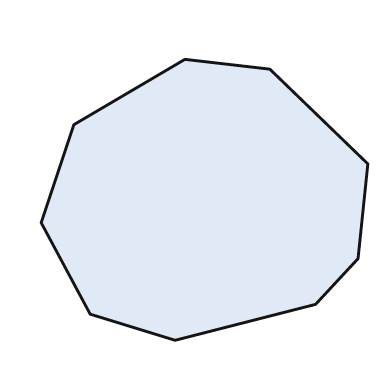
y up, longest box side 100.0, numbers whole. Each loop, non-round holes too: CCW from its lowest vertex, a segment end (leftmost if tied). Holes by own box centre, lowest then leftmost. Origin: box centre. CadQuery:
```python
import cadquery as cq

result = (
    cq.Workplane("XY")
    .moveTo(-9.0, -43.0)
    .lineTo(34.0, -32.0)
    .lineTo(47.0, -18.0)
    .lineTo(50.0, 11.0)
    .lineTo(20.0, 40.0)
    .lineTo(-6.0, 43.0)
    .lineTo(-40.0, 23.0)
    .lineTo(-50.0, -7.0)
    .lineTo(-35.0, -35.0)
    .close()
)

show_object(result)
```